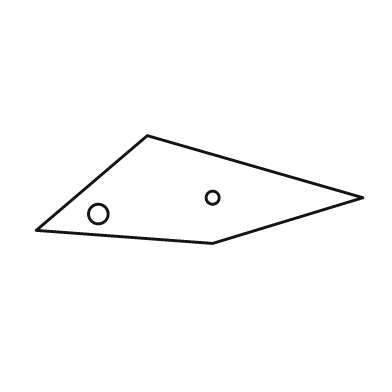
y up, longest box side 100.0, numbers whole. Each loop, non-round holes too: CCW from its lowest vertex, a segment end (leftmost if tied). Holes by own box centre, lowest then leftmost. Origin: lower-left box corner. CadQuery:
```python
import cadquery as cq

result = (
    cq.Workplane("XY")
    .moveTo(54.0, 0.0)
    .lineTo(100.0, 14.0)
    .lineTo(34.0, 33.0)
    .lineTo(0.0, 4.0)
    .close()
    .moveTo(19.0, 9.0)
    .circle(3.0)
    .moveTo(54.0, 14.0)
    .circle(2.0)
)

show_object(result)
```